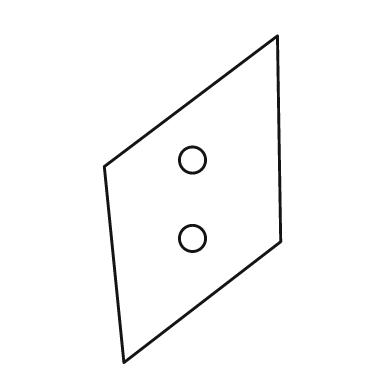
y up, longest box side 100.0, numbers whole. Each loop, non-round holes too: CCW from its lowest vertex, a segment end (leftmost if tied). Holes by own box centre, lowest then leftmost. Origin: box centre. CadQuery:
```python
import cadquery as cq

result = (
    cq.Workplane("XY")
    .moveTo(-21.0, -50.0)
    .lineTo(27.0, -13.0)
    .lineTo(26.0, 50.0)
    .lineTo(-27.0, 10.0)
    .close()
    .moveTo(0.0, -12.0)
    .circle(4.0)
    .moveTo(0.0, 12.0)
    .circle(4.0)
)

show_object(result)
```